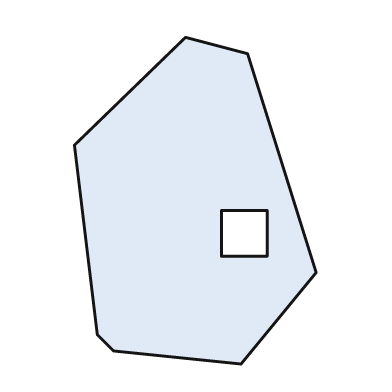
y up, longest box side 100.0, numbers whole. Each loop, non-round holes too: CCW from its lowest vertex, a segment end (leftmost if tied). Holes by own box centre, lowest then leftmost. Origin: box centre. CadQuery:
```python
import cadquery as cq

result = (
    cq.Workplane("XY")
    .moveTo(14.0, -50.0)
    .lineTo(37.0, -22.0)
    .lineTo(16.0, 45.0)
    .lineTo(-3.0, 50.0)
    .lineTo(-37.0, 17.0)
    .lineTo(-30.0, -41.0)
    .lineTo(-25.0, -46.0)
    .close()
    .moveTo(8.0, -17.0)
    .lineTo(22.0, -17.0)
    .lineTo(22.0, -3.0)
    .lineTo(8.0, -3.0)
    .close()
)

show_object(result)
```